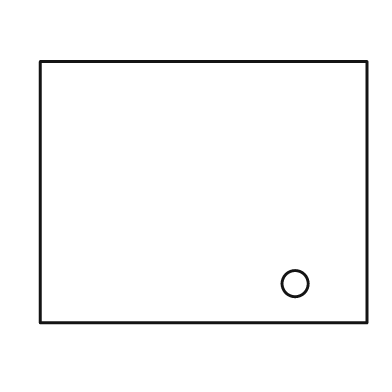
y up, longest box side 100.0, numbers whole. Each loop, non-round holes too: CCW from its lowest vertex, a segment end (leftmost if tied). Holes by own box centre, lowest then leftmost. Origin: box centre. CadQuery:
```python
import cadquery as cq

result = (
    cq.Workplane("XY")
    .moveTo(-50.0, -40.0)
    .lineTo(50.0, -40.0)
    .lineTo(50.0, 40.0)
    .lineTo(-50.0, 40.0)
    .close()
    .moveTo(28.0, -28.0)
    .circle(4.0)
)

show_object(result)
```